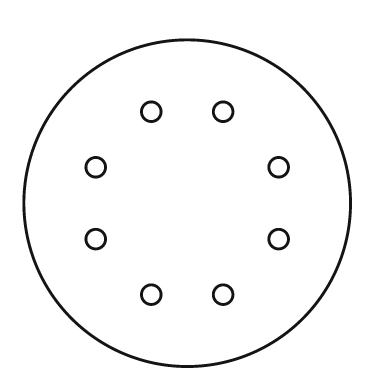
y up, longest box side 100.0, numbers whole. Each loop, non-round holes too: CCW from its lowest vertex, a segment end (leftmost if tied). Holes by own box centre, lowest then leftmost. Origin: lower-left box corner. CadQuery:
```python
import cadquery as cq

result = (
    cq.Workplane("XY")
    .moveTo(50.0, 50.0)
    .circle(50.0)
    .moveTo(39.0, 22.0)
    .circle(3.0)
    .moveTo(61.0, 22.0)
    .circle(3.0)
    .moveTo(22.0, 39.0)
    .circle(3.0)
    .moveTo(78.0, 39.0)
    .circle(3.0)
    .moveTo(22.0, 61.0)
    .circle(3.0)
    .moveTo(78.0, 61.0)
    .circle(3.0)
    .moveTo(39.0, 78.0)
    .circle(3.0)
    .moveTo(61.0, 78.0)
    .circle(3.0)
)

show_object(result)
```